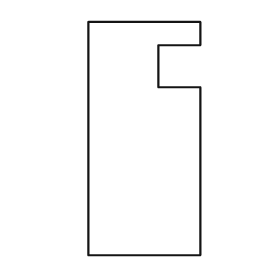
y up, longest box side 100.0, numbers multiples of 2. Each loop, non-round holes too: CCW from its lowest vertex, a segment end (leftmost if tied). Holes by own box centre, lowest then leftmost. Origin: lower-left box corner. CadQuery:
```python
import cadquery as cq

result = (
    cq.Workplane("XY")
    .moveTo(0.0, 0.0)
    .lineTo(48.0, 0.0)
    .lineTo(48.0, 72.0)
    .lineTo(30.0, 72.0)
    .lineTo(30.0, 90.0)
    .lineTo(48.0, 90.0)
    .lineTo(48.0, 100.0)
    .lineTo(0.0, 100.0)
    .close()
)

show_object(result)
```